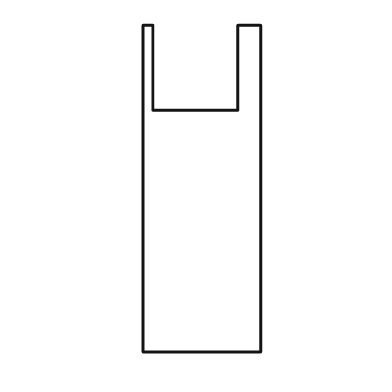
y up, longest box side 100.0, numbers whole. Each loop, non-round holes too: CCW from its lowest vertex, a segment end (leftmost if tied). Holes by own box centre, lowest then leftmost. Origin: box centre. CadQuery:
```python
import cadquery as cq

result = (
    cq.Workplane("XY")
    .moveTo(-18.0, -50.0)
    .lineTo(18.0, -50.0)
    .lineTo(18.0, 50.0)
    .lineTo(11.0, 50.0)
    .lineTo(11.0, 24.0)
    .lineTo(-15.0, 24.0)
    .lineTo(-15.0, 50.0)
    .lineTo(-18.0, 50.0)
    .close()
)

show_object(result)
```